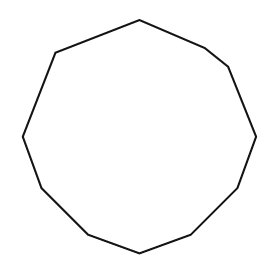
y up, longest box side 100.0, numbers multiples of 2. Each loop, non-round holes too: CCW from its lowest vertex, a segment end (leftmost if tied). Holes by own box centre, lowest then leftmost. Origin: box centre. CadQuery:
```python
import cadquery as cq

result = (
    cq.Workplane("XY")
    .moveTo(0.0, -50.0)
    .lineTo(22.0, -42.0)
    .lineTo(42.0, -22.0)
    .lineTo(50.0, 0.0)
    .lineTo(38.0, 30.0)
    .lineTo(28.0, 38.0)
    .lineTo(0.0, 50.0)
    .lineTo(-36.0, 36.0)
    .lineTo(-50.0, 0.0)
    .lineTo(-42.0, -22.0)
    .lineTo(-22.0, -42.0)
    .close()
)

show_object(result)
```